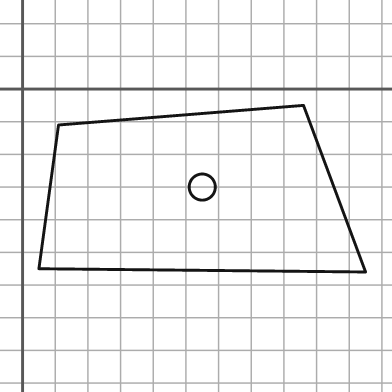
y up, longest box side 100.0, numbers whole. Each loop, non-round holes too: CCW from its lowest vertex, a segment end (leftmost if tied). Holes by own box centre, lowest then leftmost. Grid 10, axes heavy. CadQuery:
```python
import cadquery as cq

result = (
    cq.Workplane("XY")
    .moveTo(105.0, -56.0)
    .lineTo(86.0, -5.0)
    .lineTo(11.0, -11.0)
    .lineTo(5.0, -55.0)
    .close()
    .moveTo(55.0, -30.0)
    .circle(4.0)
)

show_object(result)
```